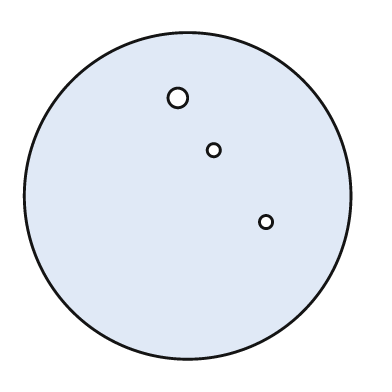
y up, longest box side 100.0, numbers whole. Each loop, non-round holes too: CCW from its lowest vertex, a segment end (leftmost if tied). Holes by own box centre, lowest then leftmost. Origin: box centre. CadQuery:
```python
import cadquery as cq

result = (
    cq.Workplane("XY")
    .moveTo(0.0, 0.0)
    .circle(50.0)
    .moveTo(24.0, -8.0)
    .circle(2.0)
    .moveTo(8.0, 14.0)
    .circle(2.0)
    .moveTo(-3.0, 30.0)
    .circle(3.0)
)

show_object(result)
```